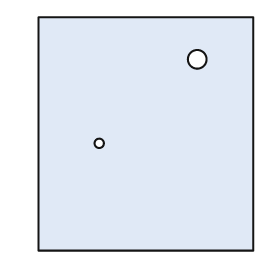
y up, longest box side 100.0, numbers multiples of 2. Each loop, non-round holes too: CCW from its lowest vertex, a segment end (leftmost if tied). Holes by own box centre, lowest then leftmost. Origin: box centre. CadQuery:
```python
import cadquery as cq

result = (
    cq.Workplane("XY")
    .moveTo(-46.0, -50.0)
    .lineTo(46.0, -50.0)
    .lineTo(46.0, 50.0)
    .lineTo(-46.0, 50.0)
    .close()
    .moveTo(-20.0, -4.0)
    .circle(2.0)
    .moveTo(22.0, 32.0)
    .circle(4.0)
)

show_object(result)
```